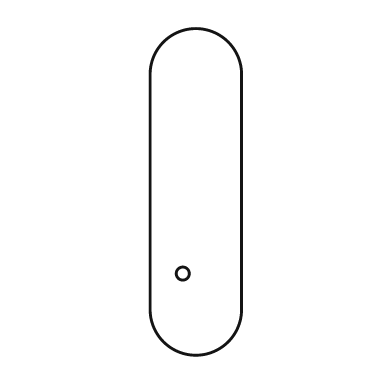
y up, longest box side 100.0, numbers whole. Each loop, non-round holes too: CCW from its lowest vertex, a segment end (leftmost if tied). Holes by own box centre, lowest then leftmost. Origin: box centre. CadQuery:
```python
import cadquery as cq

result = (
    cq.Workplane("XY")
    .moveTo(-14.0, -36.0)
    .threePointArc((0.0, -50.0), (14.0, -36.0))
    .lineTo(14.0, 36.0)
    .threePointArc((0.0, 50.0), (-14.0, 36.0))
    .close()
    .moveTo(-4.0, -25.0)
    .circle(2.0)
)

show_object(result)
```